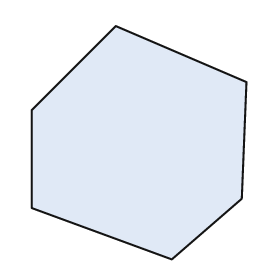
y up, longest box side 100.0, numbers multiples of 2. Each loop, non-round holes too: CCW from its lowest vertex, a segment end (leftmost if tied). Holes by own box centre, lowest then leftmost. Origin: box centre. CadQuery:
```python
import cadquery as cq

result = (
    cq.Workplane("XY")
    .moveTo(14.0, -50.0)
    .lineTo(44.0, -24.0)
    .lineTo(46.0, 26.0)
    .lineTo(-10.0, 50.0)
    .lineTo(-46.0, 14.0)
    .lineTo(-46.0, -28.0)
    .close()
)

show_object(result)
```